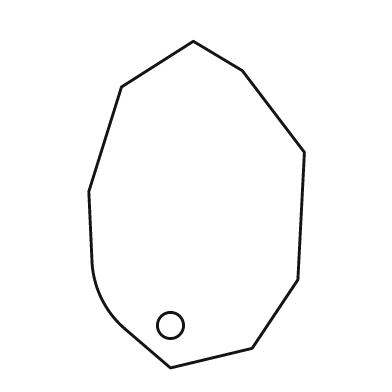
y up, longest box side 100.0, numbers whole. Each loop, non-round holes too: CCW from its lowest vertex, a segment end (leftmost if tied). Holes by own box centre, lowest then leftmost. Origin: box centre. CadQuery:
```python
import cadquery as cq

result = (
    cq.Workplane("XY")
    .moveTo(-8.0, -50.0)
    .lineTo(17.0, -44.0)
    .lineTo(31.0, -23.0)
    .lineTo(33.0, 16.0)
    .lineTo(14.0, 41.0)
    .lineTo(-1.0, 50.0)
    .lineTo(-23.0, 36.0)
    .lineTo(-33.0, 4.0)
    .lineTo(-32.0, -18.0)
    .threePointArc((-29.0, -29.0), (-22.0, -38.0))
    .close()
    .moveTo(-8.0, -37.0)
    .circle(4.0)
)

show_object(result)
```